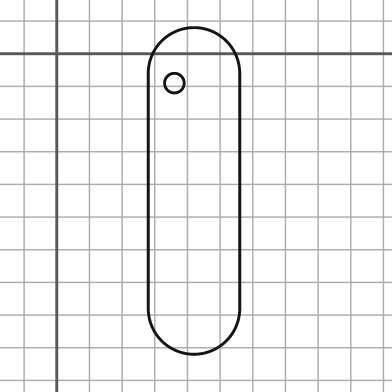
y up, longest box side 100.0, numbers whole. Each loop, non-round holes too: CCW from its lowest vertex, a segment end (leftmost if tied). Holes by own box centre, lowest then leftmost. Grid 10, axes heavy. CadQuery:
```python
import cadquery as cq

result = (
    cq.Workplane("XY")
    .moveTo(28.0, -78.0)
    .threePointArc((42.0, -92.0), (56.0, -78.0))
    .lineTo(56.0, -6.0)
    .threePointArc((42.0, 8.0), (28.0, -6.0))
    .close()
    .moveTo(36.0, -9.0)
    .circle(3.0)
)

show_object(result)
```